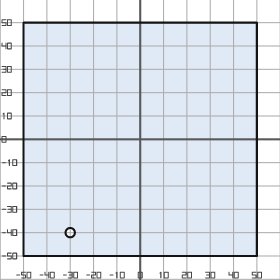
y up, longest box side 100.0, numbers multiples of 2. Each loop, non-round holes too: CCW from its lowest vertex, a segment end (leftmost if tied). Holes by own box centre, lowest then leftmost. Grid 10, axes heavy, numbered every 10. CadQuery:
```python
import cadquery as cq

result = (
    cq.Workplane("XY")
    .moveTo(-50.0, -50.0)
    .lineTo(50.0, -50.0)
    .lineTo(50.0, 50.0)
    .lineTo(-50.0, 50.0)
    .close()
    .moveTo(-30.0, -40.0)
    .circle(2.0)
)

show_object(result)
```